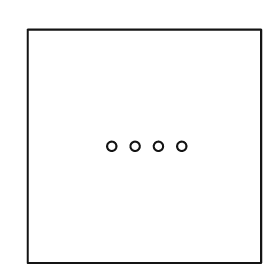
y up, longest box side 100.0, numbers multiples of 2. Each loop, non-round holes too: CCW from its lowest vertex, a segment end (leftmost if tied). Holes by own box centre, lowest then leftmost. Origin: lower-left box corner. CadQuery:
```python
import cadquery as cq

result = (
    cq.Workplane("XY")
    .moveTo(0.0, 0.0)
    .lineTo(100.0, 0.0)
    .lineTo(100.0, 100.0)
    .lineTo(0.0, 100.0)
    .close()
    .moveTo(36.0, 50.0)
    .circle(2.0)
    .moveTo(46.0, 50.0)
    .circle(2.0)
    .moveTo(56.0, 50.0)
    .circle(2.0)
    .moveTo(66.0, 50.0)
    .circle(2.0)
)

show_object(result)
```